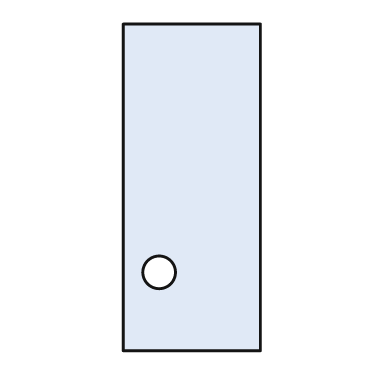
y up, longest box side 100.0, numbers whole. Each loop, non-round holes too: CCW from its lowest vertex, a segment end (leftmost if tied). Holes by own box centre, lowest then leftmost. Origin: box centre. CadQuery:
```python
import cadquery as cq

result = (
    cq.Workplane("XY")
    .moveTo(-21.0, -50.0)
    .lineTo(21.0, -50.0)
    .lineTo(21.0, 50.0)
    .lineTo(-21.0, 50.0)
    .close()
    .moveTo(-10.0, -26.0)
    .circle(5.0)
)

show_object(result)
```